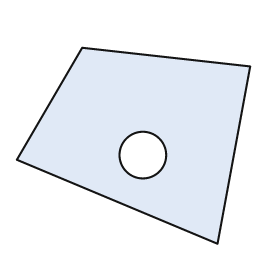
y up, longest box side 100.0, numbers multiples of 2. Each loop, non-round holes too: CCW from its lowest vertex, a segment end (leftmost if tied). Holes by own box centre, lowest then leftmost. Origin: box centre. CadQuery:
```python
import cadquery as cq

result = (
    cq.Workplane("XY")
    .moveTo(36.0, -42.0)
    .lineTo(50.0, 34.0)
    .lineTo(-22.0, 42.0)
    .lineTo(-50.0, -6.0)
    .close()
    .moveTo(4.0, -4.0)
    .circle(10.0)
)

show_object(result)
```